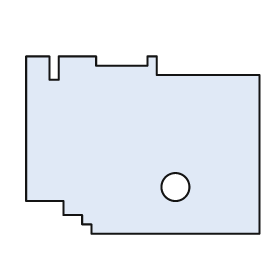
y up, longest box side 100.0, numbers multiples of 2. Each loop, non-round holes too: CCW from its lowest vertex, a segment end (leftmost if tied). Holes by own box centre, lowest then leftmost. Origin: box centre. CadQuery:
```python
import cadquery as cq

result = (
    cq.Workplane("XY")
    .moveTo(-22.0, -38.0)
    .lineTo(50.0, -38.0)
    .lineTo(50.0, 30.0)
    .lineTo(6.0, 30.0)
    .lineTo(6.0, 38.0)
    .lineTo(2.0, 38.0)
    .lineTo(2.0, 34.0)
    .lineTo(-20.0, 34.0)
    .lineTo(-20.0, 38.0)
    .lineTo(-36.0, 38.0)
    .lineTo(-36.0, 28.0)
    .lineTo(-40.0, 28.0)
    .lineTo(-40.0, 38.0)
    .lineTo(-50.0, 38.0)
    .lineTo(-50.0, -24.0)
    .lineTo(-34.0, -24.0)
    .lineTo(-34.0, -30.0)
    .lineTo(-26.0, -30.0)
    .lineTo(-26.0, -34.0)
    .lineTo(-22.0, -34.0)
    .close()
    .moveTo(14.0, -18.0)
    .circle(6.0)
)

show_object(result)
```